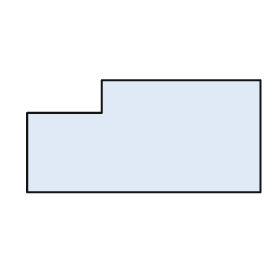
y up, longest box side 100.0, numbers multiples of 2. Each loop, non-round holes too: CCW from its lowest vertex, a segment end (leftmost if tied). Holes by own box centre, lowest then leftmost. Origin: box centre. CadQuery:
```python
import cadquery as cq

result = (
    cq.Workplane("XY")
    .moveTo(-50.0, -24.0)
    .lineTo(50.0, -24.0)
    .lineTo(50.0, 24.0)
    .lineTo(-18.0, 24.0)
    .lineTo(-18.0, 10.0)
    .lineTo(-50.0, 10.0)
    .close()
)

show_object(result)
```